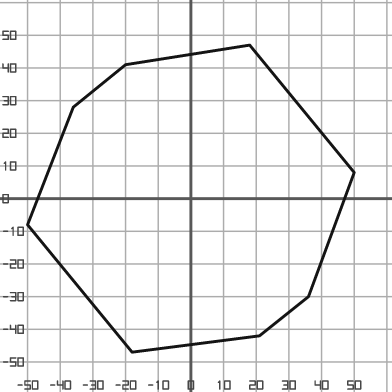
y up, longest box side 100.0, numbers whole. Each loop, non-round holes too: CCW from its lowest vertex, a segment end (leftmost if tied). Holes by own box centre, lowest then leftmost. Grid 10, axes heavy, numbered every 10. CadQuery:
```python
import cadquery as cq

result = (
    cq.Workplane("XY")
    .moveTo(-18.0, -47.0)
    .lineTo(21.0, -42.0)
    .lineTo(36.0, -30.0)
    .lineTo(50.0, 8.0)
    .lineTo(18.0, 47.0)
    .lineTo(-20.0, 41.0)
    .lineTo(-36.0, 28.0)
    .lineTo(-50.0, -8.0)
    .close()
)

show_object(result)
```